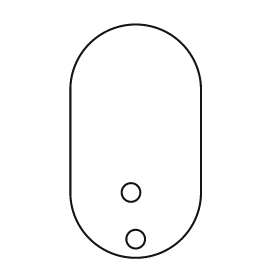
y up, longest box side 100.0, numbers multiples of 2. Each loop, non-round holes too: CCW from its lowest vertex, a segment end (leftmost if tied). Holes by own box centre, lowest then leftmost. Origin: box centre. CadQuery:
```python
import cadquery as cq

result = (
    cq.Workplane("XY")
    .moveTo(-28.0, -22.0)
    .threePointArc((0.0, -50.0), (28.0, -22.0))
    .lineTo(28.0, 22.0)
    .threePointArc((0.0, 50.0), (-28.0, 22.0))
    .close()
    .moveTo(0.0, -42.0)
    .circle(4.0)
    .moveTo(-2.0, -22.0)
    .circle(4.0)
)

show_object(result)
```